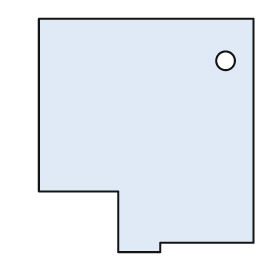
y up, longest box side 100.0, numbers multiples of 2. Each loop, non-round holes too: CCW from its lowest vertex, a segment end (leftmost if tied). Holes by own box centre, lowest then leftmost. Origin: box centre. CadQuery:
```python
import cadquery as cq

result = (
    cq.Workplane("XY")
    .moveTo(-12.0, -50.0)
    .lineTo(6.0, -50.0)
    .lineTo(6.0, -46.0)
    .lineTo(46.0, -46.0)
    .lineTo(46.0, 50.0)
    .lineTo(-46.0, 50.0)
    .lineTo(-46.0, -24.0)
    .lineTo(-12.0, -24.0)
    .close()
    .moveTo(34.0, 32.0)
    .circle(4.0)
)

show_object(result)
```